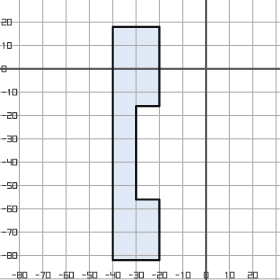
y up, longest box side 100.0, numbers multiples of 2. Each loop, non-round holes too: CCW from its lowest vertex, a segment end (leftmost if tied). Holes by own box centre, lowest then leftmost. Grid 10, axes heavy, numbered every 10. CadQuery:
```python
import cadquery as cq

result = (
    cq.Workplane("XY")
    .moveTo(-40.0, -82.0)
    .lineTo(-20.0, -82.0)
    .lineTo(-20.0, -56.0)
    .lineTo(-30.0, -56.0)
    .lineTo(-30.0, -16.0)
    .lineTo(-20.0, -16.0)
    .lineTo(-20.0, 18.0)
    .lineTo(-40.0, 18.0)
    .close()
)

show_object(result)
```